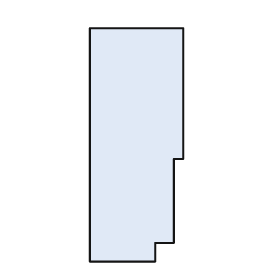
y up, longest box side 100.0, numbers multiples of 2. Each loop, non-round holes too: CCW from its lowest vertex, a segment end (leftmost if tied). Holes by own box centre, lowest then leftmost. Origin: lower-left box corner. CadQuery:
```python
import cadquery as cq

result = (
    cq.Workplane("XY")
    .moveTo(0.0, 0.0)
    .lineTo(28.0, 0.0)
    .lineTo(28.0, 8.0)
    .lineTo(36.0, 8.0)
    .lineTo(36.0, 44.0)
    .lineTo(40.0, 44.0)
    .lineTo(40.0, 100.0)
    .lineTo(0.0, 100.0)
    .close()
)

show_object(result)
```